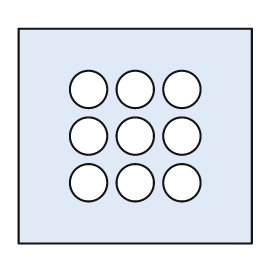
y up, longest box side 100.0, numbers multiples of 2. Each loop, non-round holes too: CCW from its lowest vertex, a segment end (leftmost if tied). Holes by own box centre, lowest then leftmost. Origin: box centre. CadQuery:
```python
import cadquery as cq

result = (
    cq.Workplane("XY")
    .moveTo(-50.0, -46.0)
    .lineTo(50.0, -46.0)
    .lineTo(50.0, 46.0)
    .lineTo(-50.0, 46.0)
    .close()
    .moveTo(-20.0, -20.0)
    .circle(8.0)
    .moveTo(0.0, -20.0)
    .circle(8.0)
    .moveTo(20.0, -20.0)
    .circle(8.0)
    .moveTo(-20.0, 0.0)
    .circle(8.0)
    .moveTo(0.0, 0.0)
    .circle(8.0)
    .moveTo(20.0, 0.0)
    .circle(8.0)
    .moveTo(-20.0, 20.0)
    .circle(8.0)
    .moveTo(0.0, 20.0)
    .circle(8.0)
    .moveTo(20.0, 20.0)
    .circle(8.0)
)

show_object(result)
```